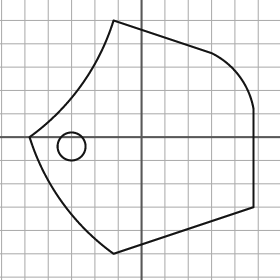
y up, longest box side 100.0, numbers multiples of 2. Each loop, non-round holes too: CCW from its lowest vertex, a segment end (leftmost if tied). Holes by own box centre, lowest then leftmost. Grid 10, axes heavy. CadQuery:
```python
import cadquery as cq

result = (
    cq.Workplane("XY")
    .moveTo(-12.0, -50.0)
    .lineTo(48.0, -30.0)
    .lineTo(48.0, 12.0)
    .threePointArc((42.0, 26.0), (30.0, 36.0))
    .lineTo(-12.0, 50.0)
    .threePointArc((-26.0, 22.0), (-48.0, 0.0))
    .threePointArc((-34.0, -28.0), (-12.0, -50.0))
    .close()
    .moveTo(-30.0, -4.0)
    .circle(6.0)
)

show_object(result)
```